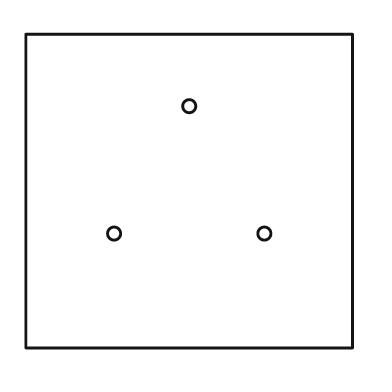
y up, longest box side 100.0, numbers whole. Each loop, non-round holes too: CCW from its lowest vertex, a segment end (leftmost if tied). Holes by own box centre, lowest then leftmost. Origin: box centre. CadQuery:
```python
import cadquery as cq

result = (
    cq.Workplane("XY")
    .moveTo(-50.0, -48.0)
    .lineTo(50.0, -48.0)
    .lineTo(50.0, 48.0)
    .lineTo(-50.0, 48.0)
    .close()
    .moveTo(-23.0, -13.0)
    .circle(2.0)
    .moveTo(23.0, -13.0)
    .circle(2.0)
    .moveTo(0.0, 26.0)
    .circle(2.0)
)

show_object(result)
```